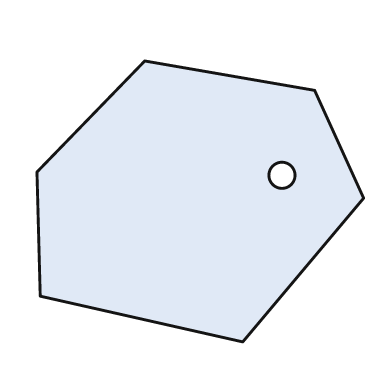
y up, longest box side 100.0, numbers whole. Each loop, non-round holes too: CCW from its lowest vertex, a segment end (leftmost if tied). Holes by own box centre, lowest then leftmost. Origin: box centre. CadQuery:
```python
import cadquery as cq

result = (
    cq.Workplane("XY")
    .moveTo(13.0, -43.0)
    .lineTo(50.0, 1.0)
    .lineTo(35.0, 34.0)
    .lineTo(-17.0, 43.0)
    .lineTo(-50.0, 9.0)
    .lineTo(-49.0, -29.0)
    .close()
    .moveTo(25.0, 8.0)
    .circle(4.0)
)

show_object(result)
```